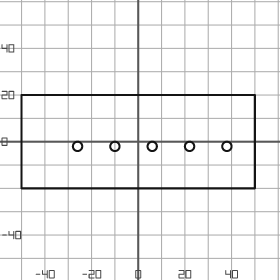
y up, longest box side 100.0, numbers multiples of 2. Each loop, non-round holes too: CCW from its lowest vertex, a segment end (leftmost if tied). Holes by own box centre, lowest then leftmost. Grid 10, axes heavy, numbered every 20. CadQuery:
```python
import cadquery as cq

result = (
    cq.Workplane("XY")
    .moveTo(-50.0, -20.0)
    .lineTo(50.0, -20.0)
    .lineTo(50.0, 20.0)
    .lineTo(-50.0, 20.0)
    .close()
    .moveTo(-26.0, -2.0)
    .circle(2.0)
    .moveTo(-10.0, -2.0)
    .circle(2.0)
    .moveTo(6.0, -2.0)
    .circle(2.0)
    .moveTo(22.0, -2.0)
    .circle(2.0)
    .moveTo(38.0, -2.0)
    .circle(2.0)
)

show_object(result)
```